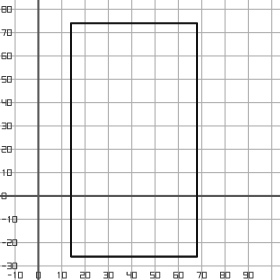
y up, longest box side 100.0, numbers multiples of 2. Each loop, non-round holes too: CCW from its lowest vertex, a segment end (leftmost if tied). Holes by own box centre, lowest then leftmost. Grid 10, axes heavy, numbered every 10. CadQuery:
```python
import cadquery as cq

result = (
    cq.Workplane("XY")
    .moveTo(14.0, -26.0)
    .lineTo(68.0, -26.0)
    .lineTo(68.0, 74.0)
    .lineTo(14.0, 74.0)
    .close()
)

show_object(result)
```